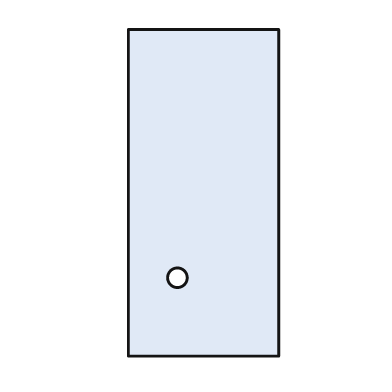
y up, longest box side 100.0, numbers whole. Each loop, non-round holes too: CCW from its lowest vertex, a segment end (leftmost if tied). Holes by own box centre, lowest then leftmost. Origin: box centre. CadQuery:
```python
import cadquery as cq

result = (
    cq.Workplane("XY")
    .moveTo(-23.0, -50.0)
    .lineTo(23.0, -50.0)
    .lineTo(23.0, 50.0)
    .lineTo(-23.0, 50.0)
    .close()
    .moveTo(-8.0, -26.0)
    .circle(3.0)
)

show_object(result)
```